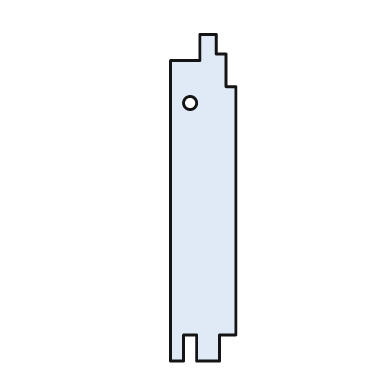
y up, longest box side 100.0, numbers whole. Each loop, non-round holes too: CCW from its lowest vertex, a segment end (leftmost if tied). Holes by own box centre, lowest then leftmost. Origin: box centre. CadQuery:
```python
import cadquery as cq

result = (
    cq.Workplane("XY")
    .moveTo(-10.0, -50.0)
    .lineTo(-6.0, -50.0)
    .lineTo(-6.0, -42.0)
    .lineTo(-2.0, -42.0)
    .lineTo(-2.0, -50.0)
    .lineTo(5.0, -50.0)
    .lineTo(5.0, -42.0)
    .lineTo(10.0, -42.0)
    .lineTo(10.0, 34.0)
    .lineTo(7.0, 34.0)
    .lineTo(7.0, 44.0)
    .lineTo(4.0, 44.0)
    .lineTo(4.0, 50.0)
    .lineTo(-1.0, 50.0)
    .lineTo(-1.0, 42.0)
    .lineTo(-10.0, 42.0)
    .close()
    .moveTo(-4.0, 29.0)
    .circle(2.0)
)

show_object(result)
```